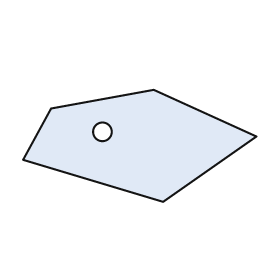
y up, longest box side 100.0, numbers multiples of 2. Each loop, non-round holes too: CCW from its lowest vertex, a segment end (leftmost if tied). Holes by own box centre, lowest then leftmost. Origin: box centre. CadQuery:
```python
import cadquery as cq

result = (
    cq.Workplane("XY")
    .moveTo(10.0, -24.0)
    .lineTo(50.0, 4.0)
    .lineTo(6.0, 24.0)
    .lineTo(-38.0, 16.0)
    .lineTo(-50.0, -6.0)
    .close()
    .moveTo(-16.0, 6.0)
    .circle(4.0)
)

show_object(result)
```